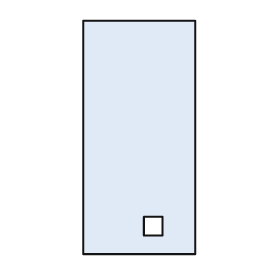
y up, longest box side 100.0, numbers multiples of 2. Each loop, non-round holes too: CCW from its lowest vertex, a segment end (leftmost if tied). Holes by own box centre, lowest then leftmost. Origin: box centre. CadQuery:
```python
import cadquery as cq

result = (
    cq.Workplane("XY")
    .moveTo(-24.0, -50.0)
    .lineTo(24.0, -50.0)
    .lineTo(24.0, 50.0)
    .lineTo(-24.0, 50.0)
    .close()
    .moveTo(2.0, -42.0)
    .lineTo(10.0, -42.0)
    .lineTo(10.0, -34.0)
    .lineTo(2.0, -34.0)
    .close()
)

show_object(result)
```